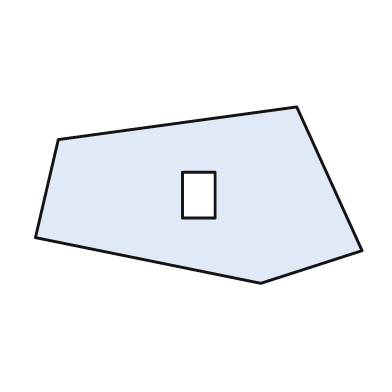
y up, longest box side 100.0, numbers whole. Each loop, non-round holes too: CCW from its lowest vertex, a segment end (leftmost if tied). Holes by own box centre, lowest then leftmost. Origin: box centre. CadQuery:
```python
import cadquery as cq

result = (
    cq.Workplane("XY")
    .moveTo(19.0, -27.0)
    .lineTo(50.0, -17.0)
    .lineTo(30.0, 27.0)
    .lineTo(-43.0, 17.0)
    .lineTo(-50.0, -13.0)
    .close()
    .moveTo(-5.0, -7.0)
    .lineTo(5.0, -7.0)
    .lineTo(5.0, 7.0)
    .lineTo(-5.0, 7.0)
    .close()
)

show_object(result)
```